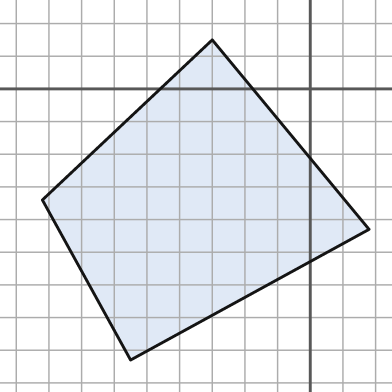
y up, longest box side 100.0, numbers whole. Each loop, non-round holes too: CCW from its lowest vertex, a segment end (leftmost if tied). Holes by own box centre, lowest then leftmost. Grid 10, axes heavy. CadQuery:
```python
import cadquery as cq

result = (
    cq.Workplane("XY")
    .moveTo(-55.0, -83.0)
    .lineTo(18.0, -43.0)
    .lineTo(-30.0, 15.0)
    .lineTo(-82.0, -34.0)
    .close()
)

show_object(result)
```